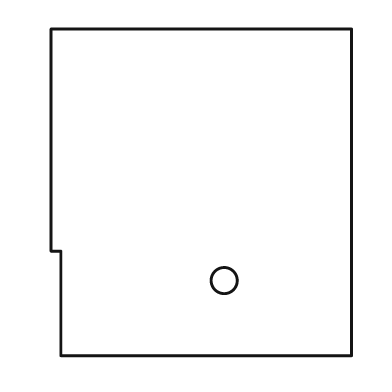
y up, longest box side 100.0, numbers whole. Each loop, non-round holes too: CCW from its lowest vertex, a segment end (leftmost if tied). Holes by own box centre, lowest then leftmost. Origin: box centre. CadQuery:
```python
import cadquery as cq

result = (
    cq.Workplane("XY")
    .moveTo(-43.0, -50.0)
    .lineTo(46.0, -50.0)
    .lineTo(46.0, 50.0)
    .lineTo(-46.0, 50.0)
    .lineTo(-46.0, -18.0)
    .lineTo(-43.0, -18.0)
    .close()
    .moveTo(7.0, -27.0)
    .circle(4.0)
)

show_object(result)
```